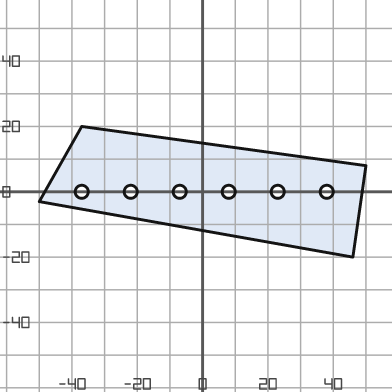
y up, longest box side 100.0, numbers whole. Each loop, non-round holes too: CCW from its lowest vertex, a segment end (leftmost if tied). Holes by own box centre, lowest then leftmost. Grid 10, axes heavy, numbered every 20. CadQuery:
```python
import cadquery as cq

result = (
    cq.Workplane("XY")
    .moveTo(46.0, -20.0)
    .lineTo(50.0, 8.0)
    .lineTo(-37.0, 20.0)
    .lineTo(-50.0, -3.0)
    .close()
    .moveTo(-37.0, 0.0)
    .circle(2.0)
    .moveTo(-22.0, 0.0)
    .circle(2.0)
    .moveTo(-7.0, 0.0)
    .circle(2.0)
    .moveTo(8.0, 0.0)
    .circle(2.0)
    .moveTo(23.0, 0.0)
    .circle(2.0)
    .moveTo(38.0, 0.0)
    .circle(2.0)
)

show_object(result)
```